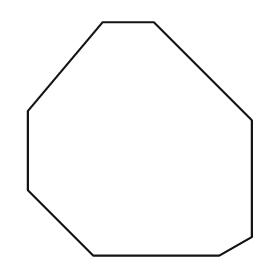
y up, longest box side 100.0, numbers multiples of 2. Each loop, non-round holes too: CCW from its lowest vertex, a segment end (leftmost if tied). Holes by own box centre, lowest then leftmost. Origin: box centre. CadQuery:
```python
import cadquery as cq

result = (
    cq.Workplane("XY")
    .moveTo(-20.0, -50.0)
    .lineTo(34.0, -50.0)
    .lineTo(48.0, -42.0)
    .lineTo(48.0, 8.0)
    .lineTo(6.0, 50.0)
    .lineTo(-16.0, 50.0)
    .lineTo(-48.0, 12.0)
    .lineTo(-48.0, -22.0)
    .close()
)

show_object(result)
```